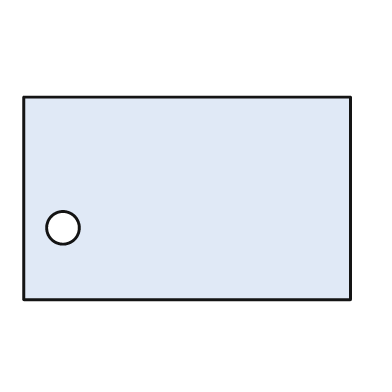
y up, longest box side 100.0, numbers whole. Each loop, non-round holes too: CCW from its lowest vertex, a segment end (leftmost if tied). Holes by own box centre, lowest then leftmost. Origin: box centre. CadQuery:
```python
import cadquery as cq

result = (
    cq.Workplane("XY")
    .moveTo(-50.0, -31.0)
    .lineTo(50.0, -31.0)
    .lineTo(50.0, 31.0)
    .lineTo(-50.0, 31.0)
    .close()
    .moveTo(-38.0, -9.0)
    .circle(5.0)
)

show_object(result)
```